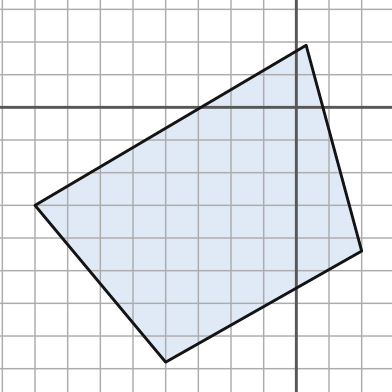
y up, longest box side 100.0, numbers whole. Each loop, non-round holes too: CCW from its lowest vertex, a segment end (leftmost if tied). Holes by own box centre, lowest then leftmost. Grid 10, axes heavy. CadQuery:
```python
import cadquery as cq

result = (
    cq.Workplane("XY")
    .moveTo(-40.0, -78.0)
    .lineTo(20.0, -44.0)
    .lineTo(3.0, 19.0)
    .lineTo(-80.0, -30.0)
    .close()
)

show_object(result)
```